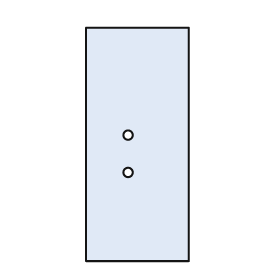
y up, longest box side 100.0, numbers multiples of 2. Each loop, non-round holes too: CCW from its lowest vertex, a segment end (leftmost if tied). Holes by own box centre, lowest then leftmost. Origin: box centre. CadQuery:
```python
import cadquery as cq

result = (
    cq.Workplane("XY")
    .moveTo(-22.0, -50.0)
    .lineTo(22.0, -50.0)
    .lineTo(22.0, 50.0)
    .lineTo(-22.0, 50.0)
    .close()
    .moveTo(-4.0, -12.0)
    .circle(2.0)
    .moveTo(-4.0, 4.0)
    .circle(2.0)
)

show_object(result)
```